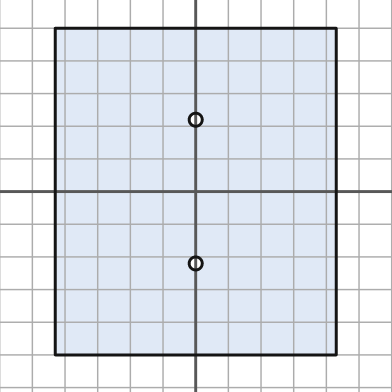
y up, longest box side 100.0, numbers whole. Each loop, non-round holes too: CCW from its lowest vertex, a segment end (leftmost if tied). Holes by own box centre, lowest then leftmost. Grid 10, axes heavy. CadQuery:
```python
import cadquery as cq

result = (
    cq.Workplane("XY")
    .moveTo(-43.0, -50.0)
    .lineTo(43.0, -50.0)
    .lineTo(43.0, 50.0)
    .lineTo(-43.0, 50.0)
    .close()
    .moveTo(0.0, -22.0)
    .circle(2.0)
    .moveTo(0.0, 22.0)
    .circle(2.0)
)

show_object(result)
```